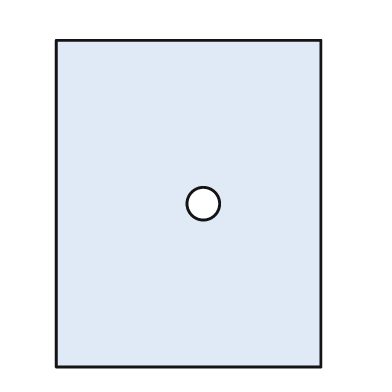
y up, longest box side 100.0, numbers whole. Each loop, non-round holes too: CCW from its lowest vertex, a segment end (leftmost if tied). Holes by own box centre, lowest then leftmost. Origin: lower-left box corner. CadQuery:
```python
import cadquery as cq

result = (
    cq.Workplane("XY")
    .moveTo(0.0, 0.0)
    .lineTo(81.0, 0.0)
    .lineTo(81.0, 100.0)
    .lineTo(0.0, 100.0)
    .close()
    .moveTo(45.0, 50.0)
    .circle(5.0)
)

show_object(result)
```